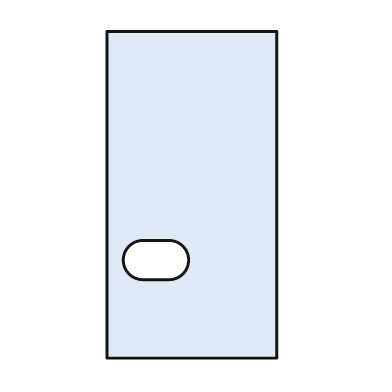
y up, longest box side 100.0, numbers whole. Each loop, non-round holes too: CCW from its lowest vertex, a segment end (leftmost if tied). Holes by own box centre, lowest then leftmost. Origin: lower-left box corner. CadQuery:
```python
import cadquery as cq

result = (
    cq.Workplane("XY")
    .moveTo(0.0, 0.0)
    .lineTo(52.0, 0.0)
    .lineTo(52.0, 100.0)
    .lineTo(0.0, 100.0)
    .close()
    .moveTo(11.0, 24.0)
    .lineTo(19.0, 24.0)
    .threePointArc((25.0, 30.0), (19.0, 36.0))
    .lineTo(11.0, 36.0)
    .threePointArc((5.0, 30.0), (11.0, 24.0))
    .close()
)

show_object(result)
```